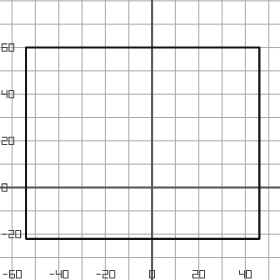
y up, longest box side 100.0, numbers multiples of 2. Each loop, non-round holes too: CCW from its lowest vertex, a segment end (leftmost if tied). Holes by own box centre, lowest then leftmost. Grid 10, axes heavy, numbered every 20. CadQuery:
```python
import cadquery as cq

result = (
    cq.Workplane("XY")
    .moveTo(-54.0, -22.0)
    .lineTo(46.0, -22.0)
    .lineTo(46.0, 60.0)
    .lineTo(-54.0, 60.0)
    .close()
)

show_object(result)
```